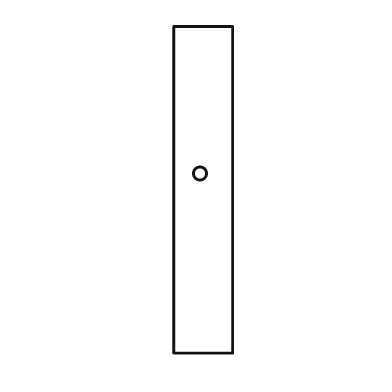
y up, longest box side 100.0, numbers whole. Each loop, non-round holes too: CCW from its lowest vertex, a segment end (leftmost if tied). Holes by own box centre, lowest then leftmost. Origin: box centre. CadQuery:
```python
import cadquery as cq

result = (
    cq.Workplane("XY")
    .moveTo(-9.0, -50.0)
    .lineTo(9.0, -50.0)
    .lineTo(9.0, 50.0)
    .lineTo(-9.0, 50.0)
    .close()
    .moveTo(-1.0, 5.0)
    .circle(2.0)
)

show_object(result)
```